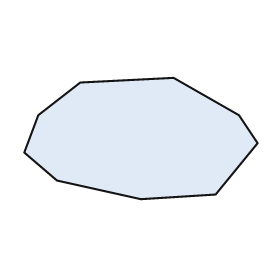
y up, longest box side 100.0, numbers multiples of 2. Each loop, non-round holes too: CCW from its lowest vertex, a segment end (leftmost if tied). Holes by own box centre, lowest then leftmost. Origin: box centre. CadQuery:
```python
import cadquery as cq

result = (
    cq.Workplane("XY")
    .moveTo(0.0, -26.0)
    .lineTo(32.0, -24.0)
    .lineTo(50.0, -2.0)
    .lineTo(42.0, 10.0)
    .lineTo(14.0, 26.0)
    .lineTo(-26.0, 24.0)
    .lineTo(-44.0, 10.0)
    .lineTo(-50.0, -6.0)
    .lineTo(-36.0, -18.0)
    .close()
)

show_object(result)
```